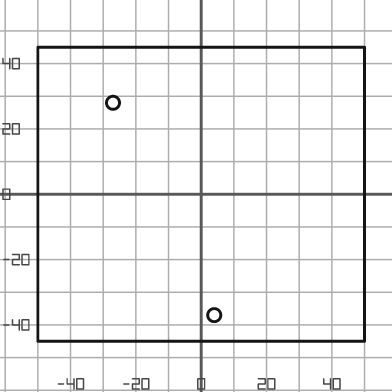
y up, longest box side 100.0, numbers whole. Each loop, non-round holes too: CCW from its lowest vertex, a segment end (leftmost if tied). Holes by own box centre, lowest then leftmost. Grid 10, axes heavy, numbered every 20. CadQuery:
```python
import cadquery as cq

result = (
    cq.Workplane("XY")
    .moveTo(-50.0, -45.0)
    .lineTo(50.0, -45.0)
    .lineTo(50.0, 45.0)
    .lineTo(-50.0, 45.0)
    .close()
    .moveTo(4.0, -37.0)
    .circle(2.0)
    .moveTo(-27.0, 28.0)
    .circle(2.0)
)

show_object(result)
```